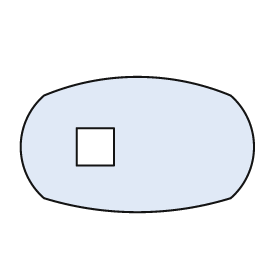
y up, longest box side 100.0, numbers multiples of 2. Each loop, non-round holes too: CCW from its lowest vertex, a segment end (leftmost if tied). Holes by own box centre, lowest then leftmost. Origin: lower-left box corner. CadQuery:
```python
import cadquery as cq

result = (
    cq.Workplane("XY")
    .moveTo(10.0, 6.0)
    .threePointArc((50.0, 0.0), (90.0, 6.0))
    .threePointArc((100.0, 28.0), (90.0, 50.0))
    .threePointArc((50.0, 58.0), (10.0, 50.0))
    .threePointArc((0.0, 28.0), (10.0, 6.0))
    .close()
    .moveTo(24.0, 20.0)
    .lineTo(40.0, 20.0)
    .lineTo(40.0, 36.0)
    .lineTo(24.0, 36.0)
    .close()
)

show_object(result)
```